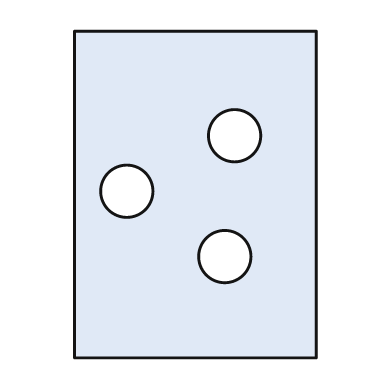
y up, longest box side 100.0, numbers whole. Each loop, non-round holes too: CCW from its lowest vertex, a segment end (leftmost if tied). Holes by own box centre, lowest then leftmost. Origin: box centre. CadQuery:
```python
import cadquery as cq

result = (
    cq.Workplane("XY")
    .moveTo(-37.0, -50.0)
    .lineTo(37.0, -50.0)
    .lineTo(37.0, 50.0)
    .lineTo(-37.0, 50.0)
    .close()
    .moveTo(9.0, -19.0)
    .circle(8.0)
    .moveTo(-21.0, 1.0)
    .circle(8.0)
    .moveTo(12.0, 18.0)
    .circle(8.0)
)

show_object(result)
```